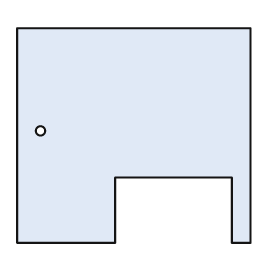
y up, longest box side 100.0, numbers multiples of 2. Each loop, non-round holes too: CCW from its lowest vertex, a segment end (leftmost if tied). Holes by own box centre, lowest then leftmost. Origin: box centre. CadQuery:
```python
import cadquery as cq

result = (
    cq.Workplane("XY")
    .moveTo(-50.0, -46.0)
    .lineTo(-8.0, -46.0)
    .lineTo(-8.0, -18.0)
    .lineTo(42.0, -18.0)
    .lineTo(42.0, -46.0)
    .lineTo(50.0, -46.0)
    .lineTo(50.0, 46.0)
    .lineTo(-50.0, 46.0)
    .close()
    .moveTo(-40.0, 2.0)
    .circle(2.0)
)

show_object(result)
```